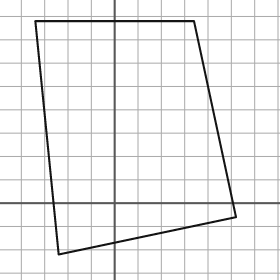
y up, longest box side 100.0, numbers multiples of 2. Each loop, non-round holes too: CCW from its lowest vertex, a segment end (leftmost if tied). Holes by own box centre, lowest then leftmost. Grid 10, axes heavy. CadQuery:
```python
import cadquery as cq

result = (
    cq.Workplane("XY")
    .moveTo(-24.0, -22.0)
    .lineTo(52.0, -6.0)
    .lineTo(34.0, 78.0)
    .lineTo(-34.0, 78.0)
    .close()
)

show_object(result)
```